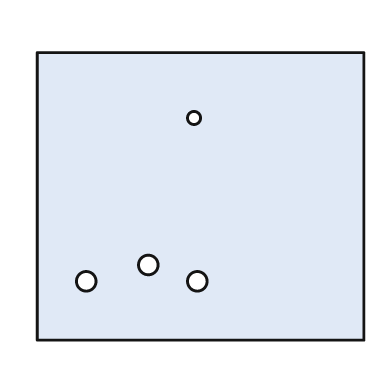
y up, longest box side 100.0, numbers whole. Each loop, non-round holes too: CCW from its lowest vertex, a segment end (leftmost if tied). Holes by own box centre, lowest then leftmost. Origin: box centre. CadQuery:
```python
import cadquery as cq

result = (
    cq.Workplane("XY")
    .moveTo(-50.0, -44.0)
    .lineTo(50.0, -44.0)
    .lineTo(50.0, 44.0)
    .lineTo(-50.0, 44.0)
    .close()
    .moveTo(-35.0, -26.0)
    .circle(3.0)
    .moveTo(-1.0, -26.0)
    .circle(3.0)
    .moveTo(-16.0, -21.0)
    .circle(3.0)
    .moveTo(-2.0, 24.0)
    .circle(2.0)
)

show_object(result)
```